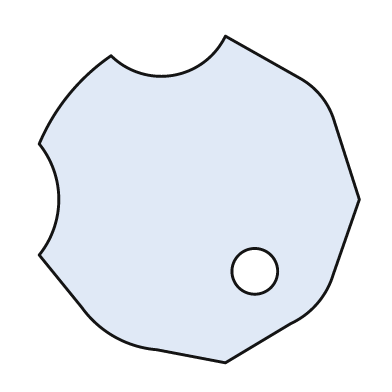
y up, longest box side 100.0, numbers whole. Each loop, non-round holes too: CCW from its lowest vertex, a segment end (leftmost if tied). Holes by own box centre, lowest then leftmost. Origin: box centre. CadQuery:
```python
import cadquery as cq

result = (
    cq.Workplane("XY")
    .moveTo(8.0, -50.0)
    .lineTo(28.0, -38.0)
    .threePointArc((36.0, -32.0), (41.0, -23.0))
    .lineTo(49.0, 0.0)
    .lineTo(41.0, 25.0)
    .threePointArc((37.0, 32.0), (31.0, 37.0))
    .lineTo(8.0, 50.0)
    .threePointArc((-8.0, 38.0), (-27.0, 44.0))
    .threePointArc((-40.0, 32.0), (-49.0, 17.0))
    .threePointArc((-43.0, 0.0), (-49.0, -17.0))
    .lineTo(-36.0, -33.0)
    .threePointArc((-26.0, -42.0), (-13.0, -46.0))
    .close()
    .moveTo(17.0, -22.0)
    .circle(7.0)
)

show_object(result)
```